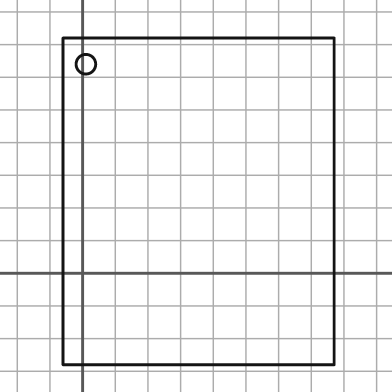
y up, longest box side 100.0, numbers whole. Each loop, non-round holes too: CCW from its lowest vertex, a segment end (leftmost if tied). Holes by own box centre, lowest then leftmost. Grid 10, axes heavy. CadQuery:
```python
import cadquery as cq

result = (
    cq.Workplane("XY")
    .moveTo(-6.0, -28.0)
    .lineTo(77.0, -28.0)
    .lineTo(77.0, 72.0)
    .lineTo(-6.0, 72.0)
    .close()
    .moveTo(1.0, 64.0)
    .circle(3.0)
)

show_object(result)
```